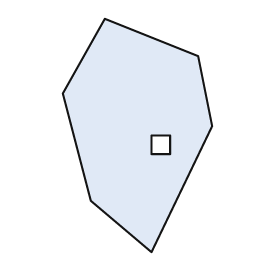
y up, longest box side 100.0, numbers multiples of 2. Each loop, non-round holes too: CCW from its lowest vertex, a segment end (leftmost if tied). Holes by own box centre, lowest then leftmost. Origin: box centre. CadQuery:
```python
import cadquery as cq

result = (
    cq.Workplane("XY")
    .moveTo(6.0, -50.0)
    .lineTo(32.0, 4.0)
    .lineTo(26.0, 34.0)
    .lineTo(-14.0, 50.0)
    .lineTo(-32.0, 18.0)
    .lineTo(-20.0, -28.0)
    .close()
    .moveTo(6.0, -8.0)
    .lineTo(14.0, -8.0)
    .lineTo(14.0, 0.0)
    .lineTo(6.0, 0.0)
    .close()
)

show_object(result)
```